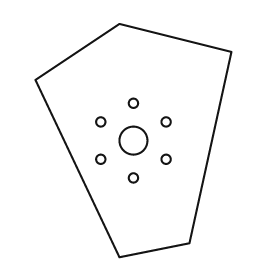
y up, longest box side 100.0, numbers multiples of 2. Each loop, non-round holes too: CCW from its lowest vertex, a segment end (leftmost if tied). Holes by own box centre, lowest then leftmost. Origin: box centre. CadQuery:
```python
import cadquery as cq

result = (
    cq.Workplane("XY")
    .moveTo(-6.0, -50.0)
    .lineTo(24.0, -44.0)
    .lineTo(42.0, 38.0)
    .lineTo(-6.0, 50.0)
    .lineTo(-42.0, 26.0)
    .close()
    .moveTo(0.0, -16.0)
    .circle(2.0)
    .moveTo(-14.0, -8.0)
    .circle(2.0)
    .moveTo(14.0, -8.0)
    .circle(2.0)
    .moveTo(0.0, 0.0)
    .circle(6.0)
    .moveTo(-14.0, 8.0)
    .circle(2.0)
    .moveTo(14.0, 8.0)
    .circle(2.0)
    .moveTo(0.0, 16.0)
    .circle(2.0)
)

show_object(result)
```